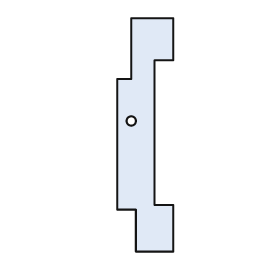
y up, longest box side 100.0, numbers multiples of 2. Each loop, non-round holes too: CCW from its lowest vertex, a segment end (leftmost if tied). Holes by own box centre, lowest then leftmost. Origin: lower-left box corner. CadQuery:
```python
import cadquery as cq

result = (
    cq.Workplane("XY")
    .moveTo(8.0, 0.0)
    .lineTo(24.0, 0.0)
    .lineTo(24.0, 20.0)
    .lineTo(16.0, 20.0)
    .lineTo(16.0, 82.0)
    .lineTo(24.0, 82.0)
    .lineTo(24.0, 100.0)
    .lineTo(6.0, 100.0)
    .lineTo(6.0, 74.0)
    .lineTo(0.0, 74.0)
    .lineTo(0.0, 18.0)
    .lineTo(8.0, 18.0)
    .close()
    .moveTo(6.0, 56.0)
    .circle(2.0)
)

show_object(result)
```